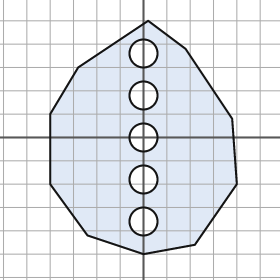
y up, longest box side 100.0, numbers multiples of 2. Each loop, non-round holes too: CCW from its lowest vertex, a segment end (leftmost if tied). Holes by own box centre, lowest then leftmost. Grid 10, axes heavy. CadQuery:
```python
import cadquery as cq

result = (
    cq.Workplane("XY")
    .moveTo(0.0, -50.0)
    .lineTo(22.0, -46.0)
    .lineTo(40.0, -20.0)
    .lineTo(38.0, 8.0)
    .lineTo(18.0, 38.0)
    .lineTo(2.0, 50.0)
    .lineTo(-28.0, 30.0)
    .lineTo(-40.0, 10.0)
    .lineTo(-40.0, -20.0)
    .lineTo(-24.0, -42.0)
    .close()
    .moveTo(0.0, -36.0)
    .circle(6.0)
    .moveTo(0.0, -18.0)
    .circle(6.0)
    .moveTo(0.0, 0.0)
    .circle(6.0)
    .moveTo(0.0, 18.0)
    .circle(6.0)
    .moveTo(0.0, 36.0)
    .circle(6.0)
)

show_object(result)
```